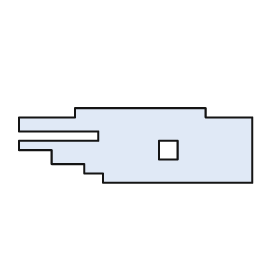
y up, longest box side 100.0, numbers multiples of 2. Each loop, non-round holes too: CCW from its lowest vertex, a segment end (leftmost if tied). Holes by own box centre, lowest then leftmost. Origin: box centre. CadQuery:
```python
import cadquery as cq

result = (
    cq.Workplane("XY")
    .moveTo(-14.0, -16.0)
    .lineTo(50.0, -16.0)
    .lineTo(50.0, 12.0)
    .lineTo(30.0, 12.0)
    .lineTo(30.0, 16.0)
    .lineTo(-26.0, 16.0)
    .lineTo(-26.0, 12.0)
    .lineTo(-50.0, 12.0)
    .lineTo(-50.0, 6.0)
    .lineTo(-16.0, 6.0)
    .lineTo(-16.0, 2.0)
    .lineTo(-50.0, 2.0)
    .lineTo(-50.0, -2.0)
    .lineTo(-36.0, -2.0)
    .lineTo(-36.0, -8.0)
    .lineTo(-22.0, -8.0)
    .lineTo(-22.0, -12.0)
    .lineTo(-14.0, -12.0)
    .close()
    .moveTo(10.0, -6.0)
    .lineTo(18.0, -6.0)
    .lineTo(18.0, 2.0)
    .lineTo(10.0, 2.0)
    .close()
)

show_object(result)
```